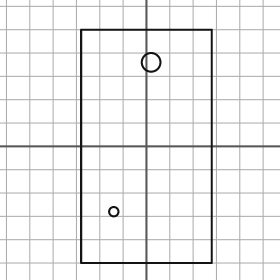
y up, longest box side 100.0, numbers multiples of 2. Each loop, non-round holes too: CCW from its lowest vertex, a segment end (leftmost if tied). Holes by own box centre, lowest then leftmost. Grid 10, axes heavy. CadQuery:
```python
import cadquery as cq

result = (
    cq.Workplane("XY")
    .moveTo(-28.0, -50.0)
    .lineTo(28.0, -50.0)
    .lineTo(28.0, 50.0)
    .lineTo(-28.0, 50.0)
    .close()
    .moveTo(-14.0, -28.0)
    .circle(2.0)
    .moveTo(2.0, 36.0)
    .circle(4.0)
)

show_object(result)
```